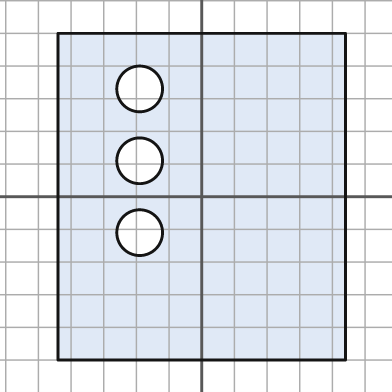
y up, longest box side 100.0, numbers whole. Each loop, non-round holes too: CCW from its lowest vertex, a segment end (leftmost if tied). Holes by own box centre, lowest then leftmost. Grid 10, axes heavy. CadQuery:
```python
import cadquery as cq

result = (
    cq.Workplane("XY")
    .moveTo(-44.0, -50.0)
    .lineTo(44.0, -50.0)
    .lineTo(44.0, 50.0)
    .lineTo(-44.0, 50.0)
    .close()
    .moveTo(-19.0, -11.0)
    .circle(7.0)
    .moveTo(-19.0, 11.0)
    .circle(7.0)
    .moveTo(-19.0, 33.0)
    .circle(7.0)
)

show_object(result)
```